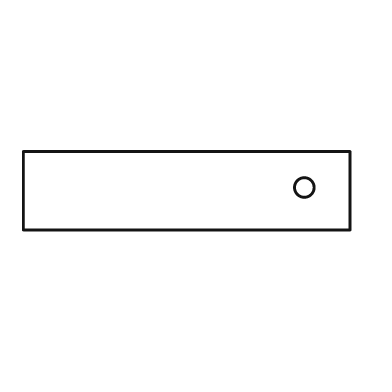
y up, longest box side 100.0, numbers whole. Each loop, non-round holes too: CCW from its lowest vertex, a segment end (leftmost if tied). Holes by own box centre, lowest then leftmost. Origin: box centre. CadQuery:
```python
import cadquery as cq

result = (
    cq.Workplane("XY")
    .moveTo(-50.0, -12.0)
    .lineTo(50.0, -12.0)
    .lineTo(50.0, 12.0)
    .lineTo(-50.0, 12.0)
    .close()
    .moveTo(36.0, 1.0)
    .circle(3.0)
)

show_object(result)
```